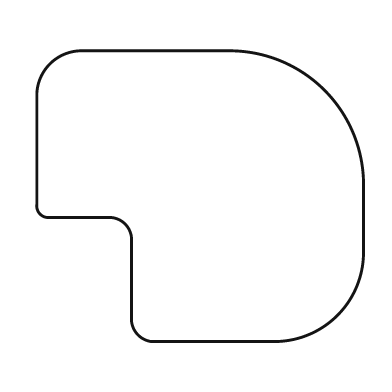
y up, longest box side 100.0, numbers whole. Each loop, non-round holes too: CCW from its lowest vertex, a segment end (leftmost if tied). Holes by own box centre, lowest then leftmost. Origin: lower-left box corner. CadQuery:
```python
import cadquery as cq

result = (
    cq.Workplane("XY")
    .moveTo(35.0, 0.0)
    .lineTo(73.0, 0.0)
    .threePointArc((92.0, 8.0), (100.0, 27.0))
    .lineTo(100.0, 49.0)
    .threePointArc((88.0, 77.0), (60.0, 89.0))
    .lineTo(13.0, 89.0)
    .threePointArc((4.0, 85.0), (0.0, 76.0))
    .lineTo(0.0, 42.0)
    .threePointArc((1.0, 39.0), (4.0, 38.0))
    .lineTo(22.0, 38.0)
    .threePointArc((27.0, 36.0), (29.0, 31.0))
    .lineTo(29.0, 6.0)
    .threePointArc((31.0, 2.0), (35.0, 0.0))
    .close()
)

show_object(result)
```